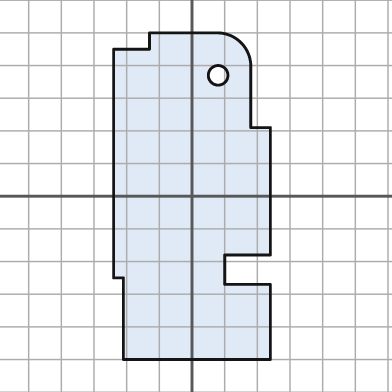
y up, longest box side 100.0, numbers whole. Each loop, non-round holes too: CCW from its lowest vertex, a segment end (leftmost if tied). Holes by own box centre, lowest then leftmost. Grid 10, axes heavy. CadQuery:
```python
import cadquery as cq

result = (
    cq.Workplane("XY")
    .moveTo(-21.0, -50.0)
    .lineTo(24.0, -50.0)
    .lineTo(24.0, -27.0)
    .lineTo(10.0, -27.0)
    .lineTo(10.0, -18.0)
    .lineTo(24.0, -18.0)
    .lineTo(24.0, 21.0)
    .lineTo(18.0, 21.0)
    .lineTo(18.0, 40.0)
    .threePointArc((15.0, 47.0), (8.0, 50.0))
    .lineTo(-13.0, 50.0)
    .lineTo(-13.0, 45.0)
    .lineTo(-24.0, 45.0)
    .lineTo(-24.0, -25.0)
    .lineTo(-21.0, -25.0)
    .close()
    .moveTo(8.0, 37.0)
    .circle(3.0)
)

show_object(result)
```